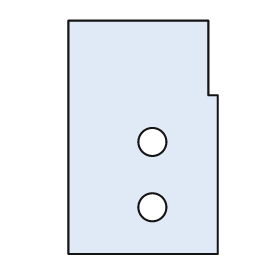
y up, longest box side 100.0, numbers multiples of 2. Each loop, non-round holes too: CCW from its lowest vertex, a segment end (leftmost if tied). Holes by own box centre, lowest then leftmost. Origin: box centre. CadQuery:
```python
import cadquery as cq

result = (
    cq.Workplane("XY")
    .moveTo(-32.0, -50.0)
    .lineTo(32.0, -50.0)
    .lineTo(32.0, 18.0)
    .lineTo(28.0, 18.0)
    .lineTo(28.0, 50.0)
    .lineTo(-32.0, 50.0)
    .close()
    .moveTo(4.0, -30.0)
    .circle(6.0)
    .moveTo(4.0, -2.0)
    .circle(6.0)
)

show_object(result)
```